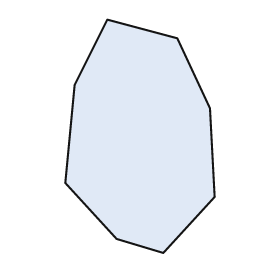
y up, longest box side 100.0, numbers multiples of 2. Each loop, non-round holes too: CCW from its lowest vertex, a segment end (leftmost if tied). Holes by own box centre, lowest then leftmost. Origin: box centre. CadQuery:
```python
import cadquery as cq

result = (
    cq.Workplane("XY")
    .moveTo(10.0, -50.0)
    .lineTo(32.0, -26.0)
    .lineTo(30.0, 12.0)
    .lineTo(16.0, 42.0)
    .lineTo(-14.0, 50.0)
    .lineTo(-28.0, 22.0)
    .lineTo(-32.0, -20.0)
    .lineTo(-10.0, -44.0)
    .close()
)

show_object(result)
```